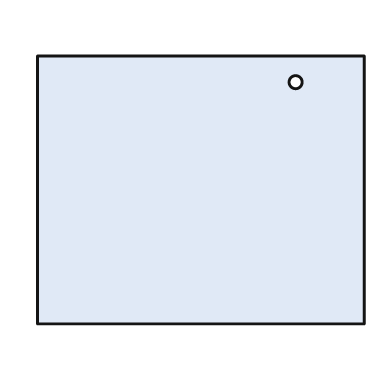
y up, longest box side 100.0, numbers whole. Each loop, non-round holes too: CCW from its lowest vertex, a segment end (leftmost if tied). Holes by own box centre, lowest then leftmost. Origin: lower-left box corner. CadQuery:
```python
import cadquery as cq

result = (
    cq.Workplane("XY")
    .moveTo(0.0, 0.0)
    .lineTo(100.0, 0.0)
    .lineTo(100.0, 82.0)
    .lineTo(0.0, 82.0)
    .close()
    .moveTo(79.0, 74.0)
    .circle(2.0)
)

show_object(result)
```